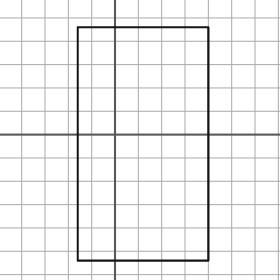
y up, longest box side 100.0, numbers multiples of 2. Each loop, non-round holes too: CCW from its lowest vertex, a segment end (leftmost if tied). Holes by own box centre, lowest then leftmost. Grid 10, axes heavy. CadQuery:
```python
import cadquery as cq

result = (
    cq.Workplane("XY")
    .moveTo(-16.0, -54.0)
    .lineTo(40.0, -54.0)
    .lineTo(40.0, 46.0)
    .lineTo(-16.0, 46.0)
    .close()
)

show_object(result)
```